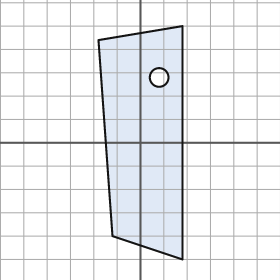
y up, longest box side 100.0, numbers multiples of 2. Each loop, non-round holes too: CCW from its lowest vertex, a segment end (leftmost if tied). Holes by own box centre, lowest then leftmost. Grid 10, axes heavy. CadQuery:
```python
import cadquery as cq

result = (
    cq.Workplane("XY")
    .moveTo(18.0, -50.0)
    .lineTo(18.0, 50.0)
    .lineTo(-18.0, 44.0)
    .lineTo(-12.0, -40.0)
    .close()
    .moveTo(8.0, 28.0)
    .circle(4.0)
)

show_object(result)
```